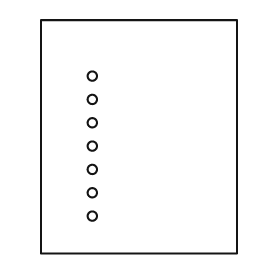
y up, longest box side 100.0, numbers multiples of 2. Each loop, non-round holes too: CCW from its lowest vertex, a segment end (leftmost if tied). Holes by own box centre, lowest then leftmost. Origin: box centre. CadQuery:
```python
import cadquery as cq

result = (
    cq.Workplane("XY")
    .moveTo(-42.0, -50.0)
    .lineTo(42.0, -50.0)
    .lineTo(42.0, 50.0)
    .lineTo(-42.0, 50.0)
    .close()
    .moveTo(-20.0, -34.0)
    .circle(2.0)
    .moveTo(-20.0, -24.0)
    .circle(2.0)
    .moveTo(-20.0, -14.0)
    .circle(2.0)
    .moveTo(-20.0, -4.0)
    .circle(2.0)
    .moveTo(-20.0, 6.0)
    .circle(2.0)
    .moveTo(-20.0, 16.0)
    .circle(2.0)
    .moveTo(-20.0, 26.0)
    .circle(2.0)
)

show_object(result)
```